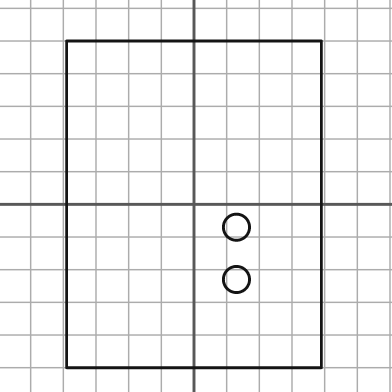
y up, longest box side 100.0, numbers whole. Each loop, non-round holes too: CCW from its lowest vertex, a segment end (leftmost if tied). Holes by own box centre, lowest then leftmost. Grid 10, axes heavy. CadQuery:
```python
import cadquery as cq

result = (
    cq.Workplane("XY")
    .moveTo(-39.0, -50.0)
    .lineTo(39.0, -50.0)
    .lineTo(39.0, 50.0)
    .lineTo(-39.0, 50.0)
    .close()
    .moveTo(13.0, -23.0)
    .circle(4.0)
    .moveTo(13.0, -7.0)
    .circle(4.0)
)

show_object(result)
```